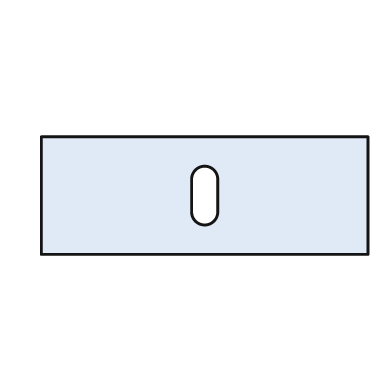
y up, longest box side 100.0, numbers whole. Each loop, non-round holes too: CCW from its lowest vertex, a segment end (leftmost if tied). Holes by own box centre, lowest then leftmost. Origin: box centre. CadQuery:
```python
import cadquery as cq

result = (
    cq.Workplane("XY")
    .moveTo(-50.0, -18.0)
    .lineTo(50.0, -18.0)
    .lineTo(50.0, 18.0)
    .lineTo(-50.0, 18.0)
    .close()
    .moveTo(-4.0, -5.0)
    .threePointArc((0.0, -9.0), (4.0, -5.0))
    .lineTo(4.0, 5.0)
    .threePointArc((0.0, 9.0), (-4.0, 5.0))
    .close()
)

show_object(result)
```